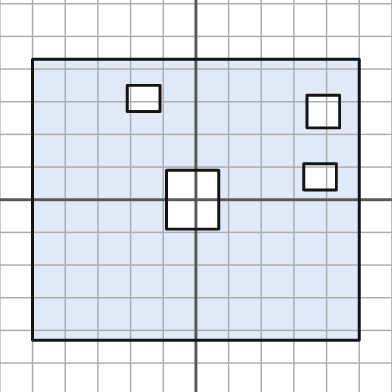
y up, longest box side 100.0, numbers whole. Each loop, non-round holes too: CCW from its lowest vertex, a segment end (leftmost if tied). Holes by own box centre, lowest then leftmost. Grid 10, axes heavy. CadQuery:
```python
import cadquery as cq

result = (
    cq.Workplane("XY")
    .moveTo(-50.0, -43.0)
    .lineTo(50.0, -43.0)
    .lineTo(50.0, 43.0)
    .lineTo(-50.0, 43.0)
    .close()
    .moveTo(-9.0, -9.0)
    .lineTo(7.0, -9.0)
    .lineTo(7.0, 9.0)
    .lineTo(-9.0, 9.0)
    .close()
    .moveTo(33.0, 3.0)
    .lineTo(43.0, 3.0)
    .lineTo(43.0, 11.0)
    .lineTo(33.0, 11.0)
    .close()
    .moveTo(34.0, 22.0)
    .lineTo(44.0, 22.0)
    .lineTo(44.0, 32.0)
    .lineTo(34.0, 32.0)
    .close()
    .moveTo(-21.0, 27.0)
    .lineTo(-11.0, 27.0)
    .lineTo(-11.0, 35.0)
    .lineTo(-21.0, 35.0)
    .close()
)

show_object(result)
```